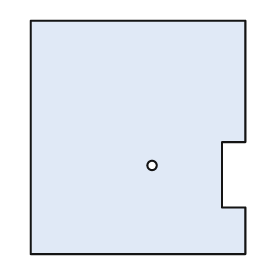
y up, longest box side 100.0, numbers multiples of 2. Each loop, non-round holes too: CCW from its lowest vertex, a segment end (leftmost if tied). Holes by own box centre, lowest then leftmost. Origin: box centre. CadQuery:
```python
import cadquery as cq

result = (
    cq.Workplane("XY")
    .moveTo(-46.0, -50.0)
    .lineTo(46.0, -50.0)
    .lineTo(46.0, -30.0)
    .lineTo(36.0, -30.0)
    .lineTo(36.0, -2.0)
    .lineTo(46.0, -2.0)
    .lineTo(46.0, 50.0)
    .lineTo(-46.0, 50.0)
    .close()
    .moveTo(6.0, -12.0)
    .circle(2.0)
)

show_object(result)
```